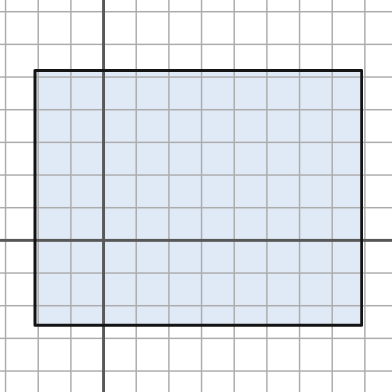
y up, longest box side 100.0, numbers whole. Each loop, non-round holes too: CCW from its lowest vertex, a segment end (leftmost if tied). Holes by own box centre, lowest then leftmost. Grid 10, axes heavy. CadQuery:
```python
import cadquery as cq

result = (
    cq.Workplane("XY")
    .moveTo(-21.0, -26.0)
    .lineTo(79.0, -26.0)
    .lineTo(79.0, 52.0)
    .lineTo(-21.0, 52.0)
    .close()
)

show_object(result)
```